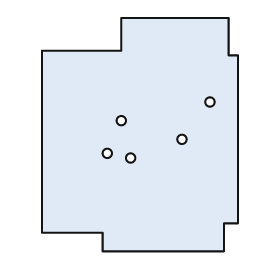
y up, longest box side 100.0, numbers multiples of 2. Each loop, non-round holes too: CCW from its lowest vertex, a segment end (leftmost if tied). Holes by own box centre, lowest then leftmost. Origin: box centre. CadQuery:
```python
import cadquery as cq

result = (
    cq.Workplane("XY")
    .moveTo(-16.0, -50.0)
    .lineTo(36.0, -50.0)
    .lineTo(36.0, -38.0)
    .lineTo(42.0, -38.0)
    .lineTo(42.0, 34.0)
    .lineTo(38.0, 34.0)
    .lineTo(38.0, 50.0)
    .lineTo(-8.0, 50.0)
    .lineTo(-8.0, 36.0)
    .lineTo(-42.0, 36.0)
    .lineTo(-42.0, -42.0)
    .lineTo(-16.0, -42.0)
    .close()
    .moveTo(-4.0, -10.0)
    .circle(2.0)
    .moveTo(-14.0, -8.0)
    .circle(2.0)
    .moveTo(18.0, -2.0)
    .circle(2.0)
    .moveTo(-8.0, 6.0)
    .circle(2.0)
    .moveTo(30.0, 14.0)
    .circle(2.0)
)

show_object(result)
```